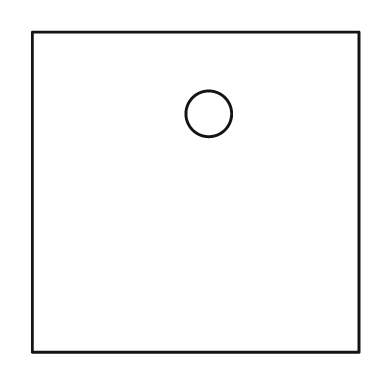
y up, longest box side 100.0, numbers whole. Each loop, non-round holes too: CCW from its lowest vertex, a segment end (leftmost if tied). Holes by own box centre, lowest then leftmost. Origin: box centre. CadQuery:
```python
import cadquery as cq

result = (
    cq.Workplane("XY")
    .moveTo(-50.0, -49.0)
    .lineTo(50.0, -49.0)
    .lineTo(50.0, 49.0)
    .lineTo(-50.0, 49.0)
    .close()
    .moveTo(4.0, 24.0)
    .circle(7.0)
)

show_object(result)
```